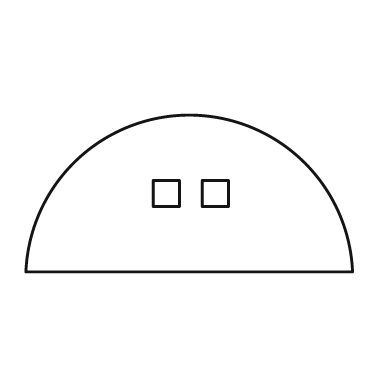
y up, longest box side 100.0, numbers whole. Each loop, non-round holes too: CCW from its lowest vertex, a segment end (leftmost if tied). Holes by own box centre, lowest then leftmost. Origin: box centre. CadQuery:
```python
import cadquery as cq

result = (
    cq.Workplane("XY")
    .moveTo(-50.0, -24.0)
    .lineTo(50.0, -24.0)
    .threePointArc((0.0, 24.0), (-50.0, -24.0))
    .close()
    .moveTo(-11.0, -4.0)
    .lineTo(-3.0, -4.0)
    .lineTo(-3.0, 4.0)
    .lineTo(-11.0, 4.0)
    .close()
    .moveTo(4.0, -4.0)
    .lineTo(12.0, -4.0)
    .lineTo(12.0, 4.0)
    .lineTo(4.0, 4.0)
    .close()
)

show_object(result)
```